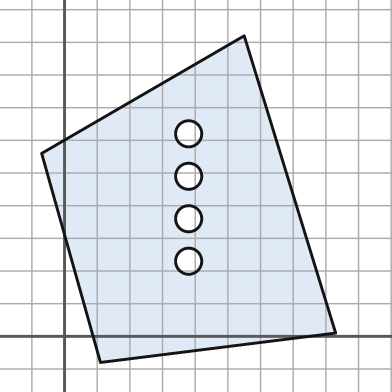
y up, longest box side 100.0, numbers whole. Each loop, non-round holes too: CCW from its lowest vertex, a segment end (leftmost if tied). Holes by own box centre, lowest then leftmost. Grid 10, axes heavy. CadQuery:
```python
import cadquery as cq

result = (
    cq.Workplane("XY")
    .moveTo(11.0, -8.0)
    .lineTo(83.0, 1.0)
    .lineTo(55.0, 92.0)
    .lineTo(-7.0, 56.0)
    .close()
    .moveTo(38.0, 23.0)
    .circle(4.0)
    .moveTo(38.0, 36.0)
    .circle(4.0)
    .moveTo(38.0, 49.0)
    .circle(4.0)
    .moveTo(38.0, 62.0)
    .circle(4.0)
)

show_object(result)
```